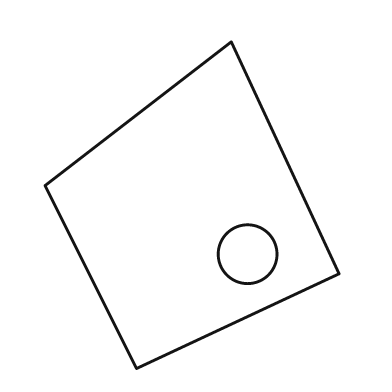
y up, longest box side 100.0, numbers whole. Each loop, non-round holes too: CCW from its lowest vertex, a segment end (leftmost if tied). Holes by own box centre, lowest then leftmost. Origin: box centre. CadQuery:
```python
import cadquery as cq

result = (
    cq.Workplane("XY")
    .moveTo(-17.0, -50.0)
    .lineTo(45.0, -21.0)
    .lineTo(12.0, 50.0)
    .lineTo(-45.0, 6.0)
    .close()
    .moveTo(17.0, -15.0)
    .circle(9.0)
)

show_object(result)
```